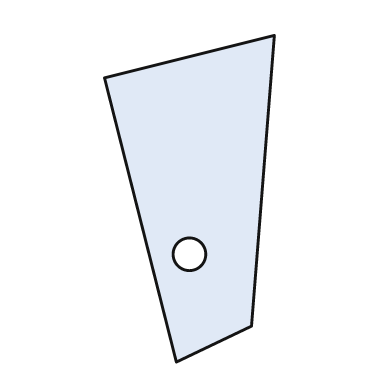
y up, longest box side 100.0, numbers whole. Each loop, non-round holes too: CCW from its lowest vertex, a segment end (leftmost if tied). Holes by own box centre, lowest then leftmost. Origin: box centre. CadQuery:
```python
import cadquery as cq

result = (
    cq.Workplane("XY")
    .moveTo(-4.0, -50.0)
    .lineTo(19.0, -39.0)
    .lineTo(26.0, 50.0)
    .lineTo(-26.0, 37.0)
    .close()
    .moveTo(0.0, -17.0)
    .circle(5.0)
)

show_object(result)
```